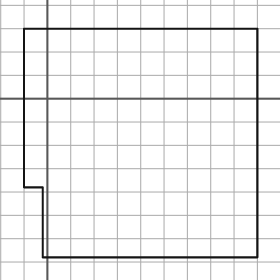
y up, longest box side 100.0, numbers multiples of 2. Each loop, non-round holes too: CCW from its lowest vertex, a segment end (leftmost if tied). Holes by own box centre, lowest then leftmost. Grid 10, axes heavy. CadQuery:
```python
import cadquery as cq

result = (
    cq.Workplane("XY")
    .moveTo(-2.0, -68.0)
    .lineTo(90.0, -68.0)
    .lineTo(90.0, 30.0)
    .lineTo(-10.0, 30.0)
    .lineTo(-10.0, -38.0)
    .lineTo(-2.0, -38.0)
    .close()
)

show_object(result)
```